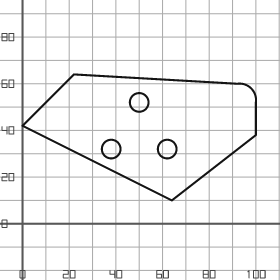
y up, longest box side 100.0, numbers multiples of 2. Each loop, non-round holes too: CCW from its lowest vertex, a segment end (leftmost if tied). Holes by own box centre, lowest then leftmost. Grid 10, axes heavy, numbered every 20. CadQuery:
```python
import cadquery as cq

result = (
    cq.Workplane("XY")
    .moveTo(64.0, 10.0)
    .lineTo(100.0, 38.0)
    .lineTo(100.0, 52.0)
    .threePointArc((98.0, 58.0), (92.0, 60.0))
    .lineTo(22.0, 64.0)
    .lineTo(0.0, 42.0)
    .close()
    .moveTo(38.0, 32.0)
    .circle(4.0)
    .moveTo(62.0, 32.0)
    .circle(4.0)
    .moveTo(50.0, 52.0)
    .circle(4.0)
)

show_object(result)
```